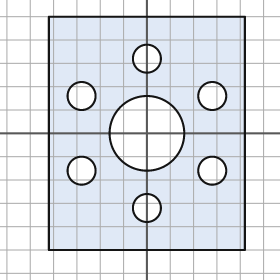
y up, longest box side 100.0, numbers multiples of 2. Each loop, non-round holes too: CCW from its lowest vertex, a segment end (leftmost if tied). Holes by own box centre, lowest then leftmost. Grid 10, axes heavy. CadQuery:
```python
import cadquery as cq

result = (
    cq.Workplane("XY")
    .moveTo(-42.0, -50.0)
    .lineTo(42.0, -50.0)
    .lineTo(42.0, 50.0)
    .lineTo(-42.0, 50.0)
    .close()
    .moveTo(0.0, -32.0)
    .circle(6.0)
    .moveTo(-28.0, -16.0)
    .circle(6.0)
    .moveTo(28.0, -16.0)
    .circle(6.0)
    .moveTo(0.0, 0.0)
    .circle(16.0)
    .moveTo(-28.0, 16.0)
    .circle(6.0)
    .moveTo(28.0, 16.0)
    .circle(6.0)
    .moveTo(0.0, 32.0)
    .circle(6.0)
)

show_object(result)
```